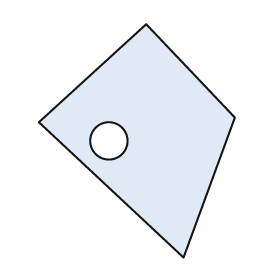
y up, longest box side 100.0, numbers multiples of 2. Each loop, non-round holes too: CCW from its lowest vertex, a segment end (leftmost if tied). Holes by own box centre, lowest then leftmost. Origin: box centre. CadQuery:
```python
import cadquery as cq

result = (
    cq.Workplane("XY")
    .moveTo(20.0, -50.0)
    .lineTo(42.0, 10.0)
    .lineTo(4.0, 50.0)
    .lineTo(-42.0, 8.0)
    .close()
    .moveTo(-12.0, 0.0)
    .circle(8.0)
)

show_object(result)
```